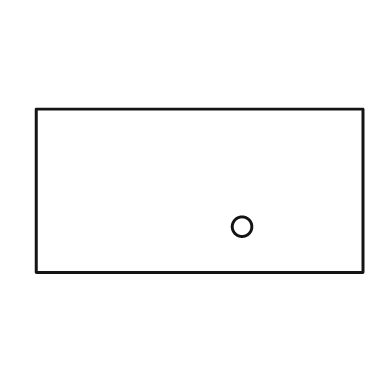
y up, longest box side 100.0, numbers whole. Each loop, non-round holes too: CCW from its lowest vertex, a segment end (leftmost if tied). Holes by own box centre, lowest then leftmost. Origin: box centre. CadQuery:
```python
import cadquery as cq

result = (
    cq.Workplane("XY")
    .moveTo(-50.0, -25.0)
    .lineTo(50.0, -25.0)
    .lineTo(50.0, 25.0)
    .lineTo(-50.0, 25.0)
    .close()
    .moveTo(13.0, -11.0)
    .circle(3.0)
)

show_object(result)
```